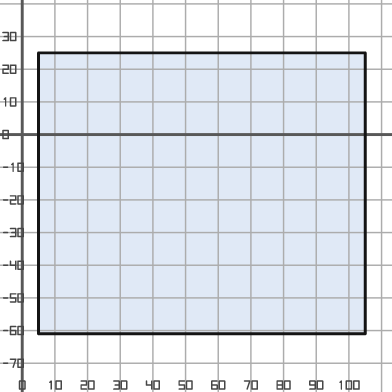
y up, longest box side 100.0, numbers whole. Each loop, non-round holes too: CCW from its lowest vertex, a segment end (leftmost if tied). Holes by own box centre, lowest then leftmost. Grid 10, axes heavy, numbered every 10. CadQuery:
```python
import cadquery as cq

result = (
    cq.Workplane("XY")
    .moveTo(5.0, -61.0)
    .lineTo(105.0, -61.0)
    .lineTo(105.0, 25.0)
    .lineTo(5.0, 25.0)
    .close()
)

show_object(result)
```